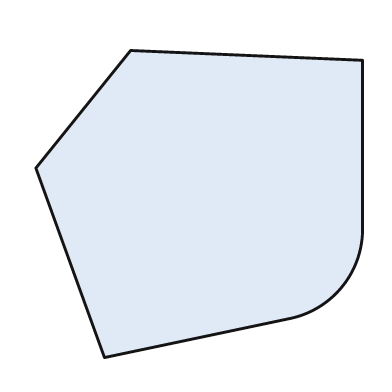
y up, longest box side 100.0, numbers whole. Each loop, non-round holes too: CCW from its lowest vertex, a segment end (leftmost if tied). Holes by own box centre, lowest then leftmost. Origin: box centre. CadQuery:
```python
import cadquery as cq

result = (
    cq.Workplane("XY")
    .moveTo(-29.0, -47.0)
    .lineTo(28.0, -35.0)
    .threePointArc((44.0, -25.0), (50.0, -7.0))
    .lineTo(50.0, 44.0)
    .lineTo(-21.0, 47.0)
    .lineTo(-50.0, 11.0)
    .close()
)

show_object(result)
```